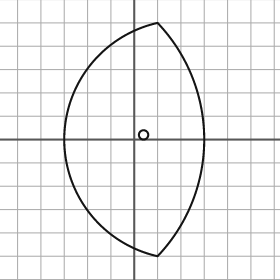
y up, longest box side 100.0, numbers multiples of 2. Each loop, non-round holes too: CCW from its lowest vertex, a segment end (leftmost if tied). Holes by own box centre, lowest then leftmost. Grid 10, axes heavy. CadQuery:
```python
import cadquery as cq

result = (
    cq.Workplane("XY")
    .moveTo(10.0, -50.0)
    .threePointArc((30.0, 0.0), (10.0, 50.0))
    .threePointArc((-30.0, 0.0), (10.0, -50.0))
    .close()
    .moveTo(4.0, 2.0)
    .circle(2.0)
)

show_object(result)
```